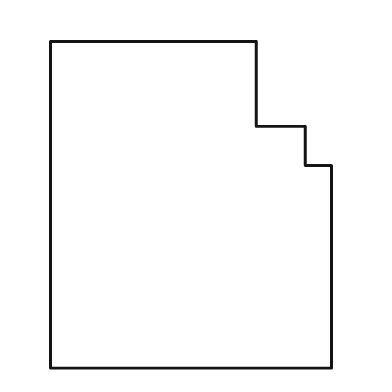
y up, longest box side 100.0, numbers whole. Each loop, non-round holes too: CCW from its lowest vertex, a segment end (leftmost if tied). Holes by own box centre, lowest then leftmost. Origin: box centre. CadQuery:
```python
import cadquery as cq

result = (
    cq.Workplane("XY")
    .moveTo(-43.0, -50.0)
    .lineTo(43.0, -50.0)
    .lineTo(43.0, 12.0)
    .lineTo(35.0, 12.0)
    .lineTo(35.0, 24.0)
    .lineTo(20.0, 24.0)
    .lineTo(20.0, 50.0)
    .lineTo(-43.0, 50.0)
    .close()
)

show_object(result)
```